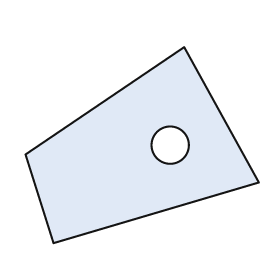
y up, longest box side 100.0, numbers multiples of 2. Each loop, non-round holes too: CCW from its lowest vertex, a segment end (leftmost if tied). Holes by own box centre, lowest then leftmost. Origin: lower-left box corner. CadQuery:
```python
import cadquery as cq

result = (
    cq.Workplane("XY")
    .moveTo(12.0, 0.0)
    .lineTo(100.0, 26.0)
    .lineTo(68.0, 84.0)
    .lineTo(0.0, 38.0)
    .close()
    .moveTo(62.0, 42.0)
    .circle(8.0)
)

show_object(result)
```